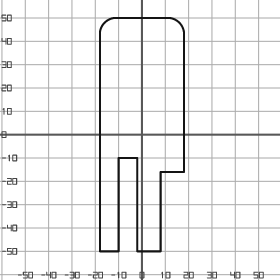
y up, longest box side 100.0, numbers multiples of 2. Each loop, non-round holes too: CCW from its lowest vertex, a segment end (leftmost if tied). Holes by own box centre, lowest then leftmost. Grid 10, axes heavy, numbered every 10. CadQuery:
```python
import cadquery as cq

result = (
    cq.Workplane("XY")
    .moveTo(-18.0, -50.0)
    .lineTo(-10.0, -50.0)
    .lineTo(-10.0, -10.0)
    .lineTo(-2.0, -10.0)
    .lineTo(-2.0, -50.0)
    .lineTo(8.0, -50.0)
    .lineTo(8.0, -16.0)
    .lineTo(18.0, -16.0)
    .lineTo(18.0, 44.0)
    .threePointArc((16.0, 48.0), (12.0, 50.0))
    .lineTo(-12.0, 50.0)
    .threePointArc((-16.0, 48.0), (-18.0, 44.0))
    .close()
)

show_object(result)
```